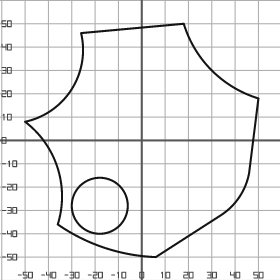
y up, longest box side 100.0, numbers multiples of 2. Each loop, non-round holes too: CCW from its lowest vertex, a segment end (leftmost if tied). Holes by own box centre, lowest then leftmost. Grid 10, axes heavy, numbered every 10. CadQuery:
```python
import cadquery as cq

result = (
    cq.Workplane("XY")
    .moveTo(6.0, -50.0)
    .lineTo(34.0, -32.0)
    .threePointArc((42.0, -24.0), (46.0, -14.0))
    .lineTo(50.0, 18.0)
    .threePointArc((30.0, 30.0), (18.0, 50.0))
    .lineTo(-26.0, 46.0)
    .threePointArc((-30.0, 22.0), (-50.0, 8.0))
    .threePointArc((-36.0, -12.0), (-36.0, -36.0))
    .threePointArc((-16.0, -46.0), (6.0, -50.0))
    .close()
    .moveTo(-18.0, -28.0)
    .circle(12.0)
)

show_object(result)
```